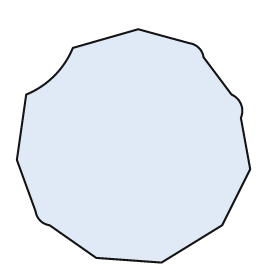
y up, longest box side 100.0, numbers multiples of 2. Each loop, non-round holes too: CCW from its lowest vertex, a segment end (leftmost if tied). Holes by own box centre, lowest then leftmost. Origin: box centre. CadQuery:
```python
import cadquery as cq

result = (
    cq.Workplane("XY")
    .moveTo(12.0, -50.0)
    .lineTo(38.0, -34.0)
    .lineTo(50.0, -10.0)
    .lineTo(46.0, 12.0)
    .threePointArc((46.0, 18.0), (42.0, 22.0))
    .lineTo(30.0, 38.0)
    .threePointArc((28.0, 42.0), (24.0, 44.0))
    .lineTo(2.0, 50.0)
    .lineTo(-26.0, 42.0)
    .threePointArc((-34.0, 30.0), (-46.0, 22.0))
    .lineTo(-50.0, -6.0)
    .lineTo(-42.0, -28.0)
    .threePointArc((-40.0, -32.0), (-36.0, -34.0))
    .lineTo(-16.0, -48.0)
    .close()
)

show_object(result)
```